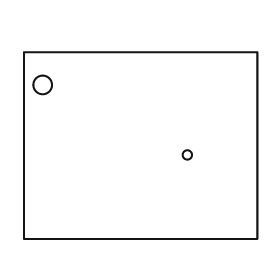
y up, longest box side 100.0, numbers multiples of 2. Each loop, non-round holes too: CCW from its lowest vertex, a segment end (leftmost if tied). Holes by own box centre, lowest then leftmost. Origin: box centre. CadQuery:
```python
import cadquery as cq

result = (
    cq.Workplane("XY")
    .moveTo(-50.0, -40.0)
    .lineTo(50.0, -40.0)
    .lineTo(50.0, 40.0)
    .lineTo(-50.0, 40.0)
    .close()
    .moveTo(20.0, -4.0)
    .circle(2.0)
    .moveTo(-42.0, 26.0)
    .circle(4.0)
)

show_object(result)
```